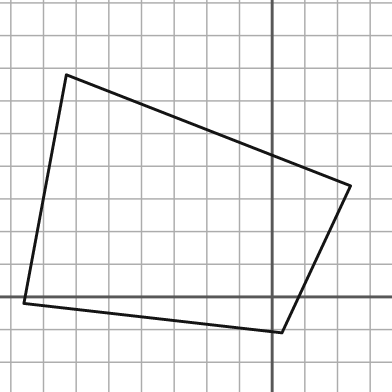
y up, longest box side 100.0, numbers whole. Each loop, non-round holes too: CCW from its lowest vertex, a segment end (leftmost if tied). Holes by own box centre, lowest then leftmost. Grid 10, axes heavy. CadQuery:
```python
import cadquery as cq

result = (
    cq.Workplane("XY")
    .moveTo(3.0, -11.0)
    .lineTo(24.0, 34.0)
    .lineTo(-63.0, 68.0)
    .lineTo(-76.0, -2.0)
    .close()
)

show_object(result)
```